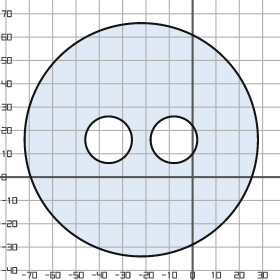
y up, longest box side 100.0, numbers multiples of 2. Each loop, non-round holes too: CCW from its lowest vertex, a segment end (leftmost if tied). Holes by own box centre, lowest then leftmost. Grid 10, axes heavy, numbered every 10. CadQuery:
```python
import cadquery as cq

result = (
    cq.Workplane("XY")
    .moveTo(-22.0, 16.0)
    .circle(50.0)
    .moveTo(-36.0, 16.0)
    .circle(10.0)
    .moveTo(-8.0, 16.0)
    .circle(10.0)
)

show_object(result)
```